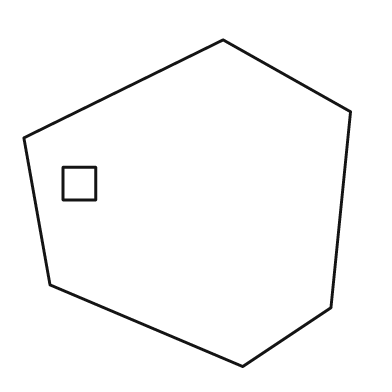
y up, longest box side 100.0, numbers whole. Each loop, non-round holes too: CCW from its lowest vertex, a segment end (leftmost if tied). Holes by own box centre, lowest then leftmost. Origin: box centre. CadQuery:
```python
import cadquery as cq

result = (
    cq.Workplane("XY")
    .moveTo(17.0, -50.0)
    .lineTo(44.0, -32.0)
    .lineTo(50.0, 28.0)
    .lineTo(11.0, 50.0)
    .lineTo(-50.0, 20.0)
    .lineTo(-42.0, -25.0)
    .close()
    .moveTo(-38.0, 1.0)
    .lineTo(-28.0, 1.0)
    .lineTo(-28.0, 11.0)
    .lineTo(-38.0, 11.0)
    .close()
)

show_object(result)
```